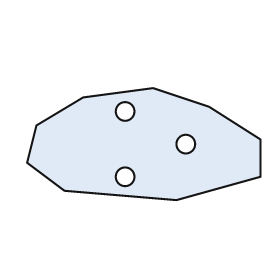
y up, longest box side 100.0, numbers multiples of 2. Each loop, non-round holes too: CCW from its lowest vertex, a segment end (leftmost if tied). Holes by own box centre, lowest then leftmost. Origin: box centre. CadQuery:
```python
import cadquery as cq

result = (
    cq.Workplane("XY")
    .moveTo(14.0, -24.0)
    .lineTo(50.0, -14.0)
    .lineTo(50.0, 2.0)
    .lineTo(28.0, 16.0)
    .lineTo(4.0, 24.0)
    .lineTo(-26.0, 20.0)
    .lineTo(-46.0, 8.0)
    .lineTo(-50.0, -8.0)
    .lineTo(-34.0, -20.0)
    .close()
    .moveTo(-8.0, -14.0)
    .circle(4.0)
    .moveTo(18.0, 0.0)
    .circle(4.0)
    .moveTo(-8.0, 14.0)
    .circle(4.0)
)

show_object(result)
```